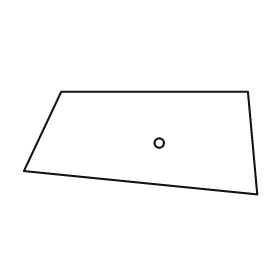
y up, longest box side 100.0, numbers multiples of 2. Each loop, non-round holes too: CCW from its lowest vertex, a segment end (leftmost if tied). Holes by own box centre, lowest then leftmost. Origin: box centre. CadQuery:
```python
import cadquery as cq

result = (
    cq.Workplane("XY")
    .moveTo(50.0, -22.0)
    .lineTo(46.0, 22.0)
    .lineTo(-34.0, 22.0)
    .lineTo(-50.0, -12.0)
    .close()
    .moveTo(8.0, 0.0)
    .circle(2.0)
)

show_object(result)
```